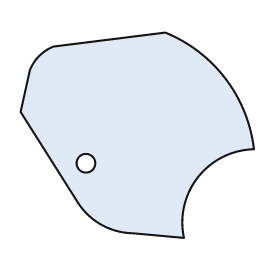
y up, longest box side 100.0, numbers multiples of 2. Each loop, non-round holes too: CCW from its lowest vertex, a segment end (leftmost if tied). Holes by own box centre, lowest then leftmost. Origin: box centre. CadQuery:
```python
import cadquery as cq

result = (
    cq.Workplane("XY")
    .moveTo(20.0, -44.0)
    .threePointArc((26.0, -18.0), (50.0, -6.0))
    .threePointArc((38.0, 24.0), (12.0, 44.0))
    .lineTo(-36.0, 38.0)
    .threePointArc((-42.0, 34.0), (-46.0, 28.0))
    .lineTo(-50.0, 10.0)
    .lineTo(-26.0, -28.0)
    .threePointArc((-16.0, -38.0), (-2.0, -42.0))
    .close()
    .moveTo(-22.0, -12.0)
    .circle(4.0)
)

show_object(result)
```